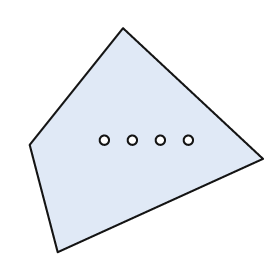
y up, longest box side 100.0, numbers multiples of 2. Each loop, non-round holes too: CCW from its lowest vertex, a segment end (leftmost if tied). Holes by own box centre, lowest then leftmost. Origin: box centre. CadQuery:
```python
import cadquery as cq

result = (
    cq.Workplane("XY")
    .moveTo(-38.0, -48.0)
    .lineTo(50.0, -8.0)
    .lineTo(-10.0, 48.0)
    .lineTo(-50.0, -2.0)
    .close()
    .moveTo(-18.0, 0.0)
    .circle(2.0)
    .moveTo(-6.0, 0.0)
    .circle(2.0)
    .moveTo(6.0, 0.0)
    .circle(2.0)
    .moveTo(18.0, 0.0)
    .circle(2.0)
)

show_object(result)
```